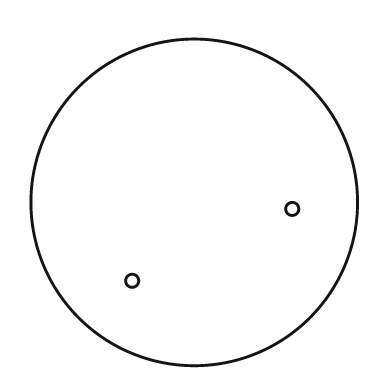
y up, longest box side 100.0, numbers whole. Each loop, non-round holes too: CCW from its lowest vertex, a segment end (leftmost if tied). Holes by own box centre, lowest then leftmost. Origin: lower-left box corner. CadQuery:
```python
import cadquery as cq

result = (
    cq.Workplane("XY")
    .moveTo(50.0, 50.0)
    .circle(50.0)
    .moveTo(31.0, 26.0)
    .circle(2.0)
    .moveTo(80.0, 48.0)
    .circle(2.0)
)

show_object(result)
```